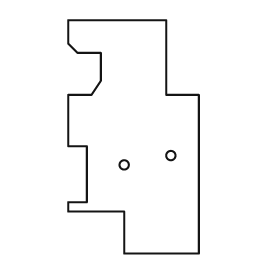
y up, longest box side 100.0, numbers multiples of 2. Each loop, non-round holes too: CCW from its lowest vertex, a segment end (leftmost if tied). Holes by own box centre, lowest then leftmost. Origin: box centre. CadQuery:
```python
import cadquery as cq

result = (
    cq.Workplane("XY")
    .moveTo(-4.0, -50.0)
    .lineTo(28.0, -50.0)
    .lineTo(28.0, 18.0)
    .lineTo(14.0, 18.0)
    .lineTo(14.0, 50.0)
    .lineTo(-28.0, 50.0)
    .lineTo(-28.0, 40.0)
    .lineTo(-24.0, 36.0)
    .lineTo(-14.0, 36.0)
    .lineTo(-14.0, 24.0)
    .lineTo(-18.0, 18.0)
    .lineTo(-28.0, 18.0)
    .lineTo(-28.0, -4.0)
    .lineTo(-20.0, -4.0)
    .lineTo(-20.0, -28.0)
    .lineTo(-28.0, -28.0)
    .lineTo(-28.0, -32.0)
    .lineTo(-4.0, -32.0)
    .close()
    .moveTo(-4.0, -12.0)
    .circle(2.0)
    .moveTo(16.0, -8.0)
    .circle(2.0)
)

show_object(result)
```